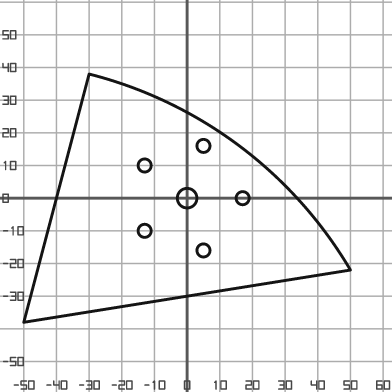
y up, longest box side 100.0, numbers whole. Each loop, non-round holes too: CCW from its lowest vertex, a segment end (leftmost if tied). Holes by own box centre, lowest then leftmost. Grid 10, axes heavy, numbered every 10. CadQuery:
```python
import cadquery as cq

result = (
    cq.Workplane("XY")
    .moveTo(-50.0, -38.0)
    .lineTo(50.0, -22.0)
    .threePointArc((16.0, 16.0), (-30.0, 38.0))
    .close()
    .moveTo(5.0, -16.0)
    .circle(2.0)
    .moveTo(-13.0, -10.0)
    .circle(2.0)
    .moveTo(0.0, 0.0)
    .circle(3.0)
    .moveTo(17.0, 0.0)
    .circle(2.0)
    .moveTo(-13.0, 10.0)
    .circle(2.0)
    .moveTo(5.0, 16.0)
    .circle(2.0)
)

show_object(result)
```